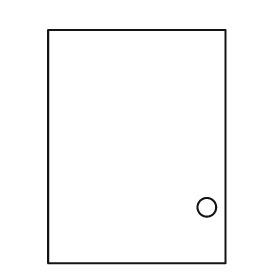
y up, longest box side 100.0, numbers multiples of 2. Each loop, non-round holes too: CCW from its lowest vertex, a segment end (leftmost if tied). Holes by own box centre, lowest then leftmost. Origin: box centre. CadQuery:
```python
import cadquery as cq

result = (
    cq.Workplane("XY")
    .moveTo(-38.0, -50.0)
    .lineTo(38.0, -50.0)
    .lineTo(38.0, 50.0)
    .lineTo(-38.0, 50.0)
    .close()
    .moveTo(30.0, -26.0)
    .circle(4.0)
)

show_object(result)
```